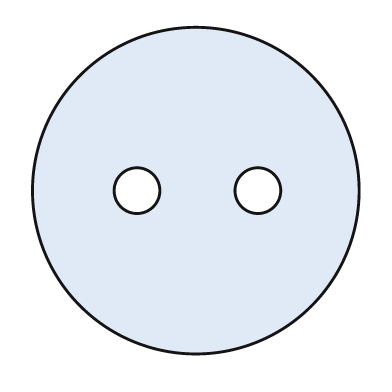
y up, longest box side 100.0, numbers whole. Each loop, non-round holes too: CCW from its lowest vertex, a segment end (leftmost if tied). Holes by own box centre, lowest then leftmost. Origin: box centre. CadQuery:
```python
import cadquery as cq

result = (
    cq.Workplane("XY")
    .moveTo(0.0, 0.0)
    .circle(50.0)
    .moveTo(-18.0, 0.0)
    .circle(7.0)
    .moveTo(19.0, 0.0)
    .circle(7.0)
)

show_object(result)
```